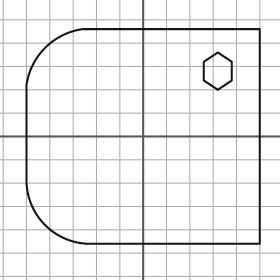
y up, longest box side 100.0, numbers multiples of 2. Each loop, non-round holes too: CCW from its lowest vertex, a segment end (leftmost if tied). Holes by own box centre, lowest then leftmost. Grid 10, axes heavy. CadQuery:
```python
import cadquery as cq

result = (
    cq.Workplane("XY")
    .moveTo(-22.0, -46.0)
    .lineTo(50.0, -46.0)
    .lineTo(50.0, 46.0)
    .lineTo(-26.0, 46.0)
    .threePointArc((-42.0, 38.0), (-50.0, 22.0))
    .lineTo(-50.0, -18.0)
    .threePointArc((-42.0, -38.0), (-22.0, -46.0))
    .close()
    .moveTo(32.0, 20.0)
    .lineTo(38.0, 24.0)
    .lineTo(38.0, 32.0)
    .lineTo(32.0, 36.0)
    .lineTo(26.0, 32.0)
    .lineTo(26.0, 24.0)
    .close()
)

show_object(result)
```